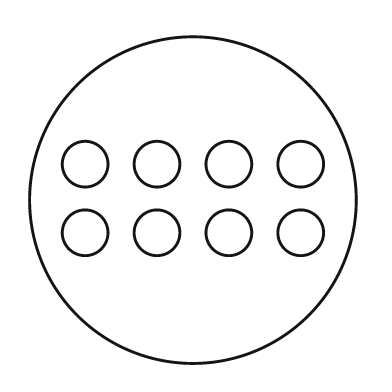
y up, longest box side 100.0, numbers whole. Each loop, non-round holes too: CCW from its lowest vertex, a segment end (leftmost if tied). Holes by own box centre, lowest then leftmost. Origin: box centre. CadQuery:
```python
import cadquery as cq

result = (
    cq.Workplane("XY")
    .moveTo(0.0, 0.0)
    .circle(50.0)
    .moveTo(-33.0, -10.0)
    .circle(7.0)
    .moveTo(-11.0, -10.0)
    .circle(7.0)
    .moveTo(11.0, -10.0)
    .circle(7.0)
    .moveTo(33.0, -10.0)
    .circle(7.0)
    .moveTo(-33.0, 11.0)
    .circle(7.0)
    .moveTo(-11.0, 11.0)
    .circle(7.0)
    .moveTo(11.0, 11.0)
    .circle(7.0)
    .moveTo(33.0, 11.0)
    .circle(7.0)
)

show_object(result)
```